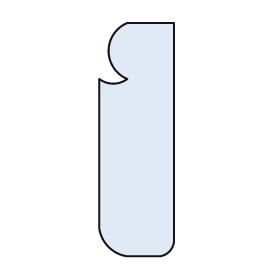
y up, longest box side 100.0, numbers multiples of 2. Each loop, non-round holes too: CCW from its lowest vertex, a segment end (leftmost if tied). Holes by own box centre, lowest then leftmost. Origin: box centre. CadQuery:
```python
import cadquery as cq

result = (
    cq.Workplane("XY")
    .moveTo(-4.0, -50.0)
    .lineTo(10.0, -50.0)
    .threePointArc((14.0, -48.0), (16.0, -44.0))
    .lineTo(16.0, 50.0)
    .lineTo(-4.0, 50.0)
    .threePointArc((-12.0, 38.0), (-4.0, 26.0))
    .threePointArc((-10.0, 24.0), (-16.0, 26.0))
    .lineTo(-16.0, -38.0)
    .threePointArc((-12.0, -46.0), (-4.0, -50.0))
    .close()
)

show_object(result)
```